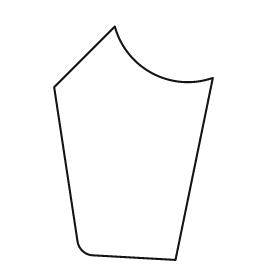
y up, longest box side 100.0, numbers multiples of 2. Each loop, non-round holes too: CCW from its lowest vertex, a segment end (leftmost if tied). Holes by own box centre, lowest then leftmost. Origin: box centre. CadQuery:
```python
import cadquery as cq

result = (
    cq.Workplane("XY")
    .moveTo(18.0, -50.0)
    .lineTo(34.0, 28.0)
    .threePointArc((8.0, 30.0), (-8.0, 50.0))
    .lineTo(-34.0, 24.0)
    .lineTo(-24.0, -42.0)
    .threePointArc((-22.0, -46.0), (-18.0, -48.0))
    .close()
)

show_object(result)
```